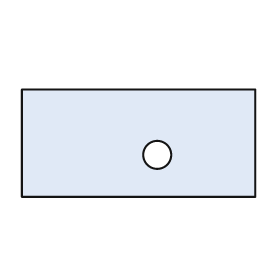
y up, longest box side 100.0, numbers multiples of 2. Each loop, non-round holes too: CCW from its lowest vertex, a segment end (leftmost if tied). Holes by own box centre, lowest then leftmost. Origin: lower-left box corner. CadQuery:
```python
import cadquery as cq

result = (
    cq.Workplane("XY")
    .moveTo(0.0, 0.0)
    .lineTo(100.0, 0.0)
    .lineTo(100.0, 46.0)
    .lineTo(0.0, 46.0)
    .close()
    .moveTo(58.0, 18.0)
    .circle(6.0)
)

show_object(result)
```